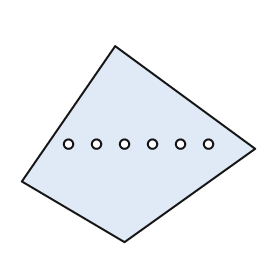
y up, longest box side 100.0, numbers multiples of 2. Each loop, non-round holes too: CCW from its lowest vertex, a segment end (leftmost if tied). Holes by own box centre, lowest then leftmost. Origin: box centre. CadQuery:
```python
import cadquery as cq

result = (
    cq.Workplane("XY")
    .moveTo(-6.0, -42.0)
    .lineTo(50.0, -2.0)
    .lineTo(-10.0, 42.0)
    .lineTo(-50.0, -16.0)
    .close()
    .moveTo(-30.0, 0.0)
    .circle(2.0)
    .moveTo(-18.0, 0.0)
    .circle(2.0)
    .moveTo(-6.0, 0.0)
    .circle(2.0)
    .moveTo(6.0, 0.0)
    .circle(2.0)
    .moveTo(18.0, 0.0)
    .circle(2.0)
    .moveTo(30.0, 0.0)
    .circle(2.0)
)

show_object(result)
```